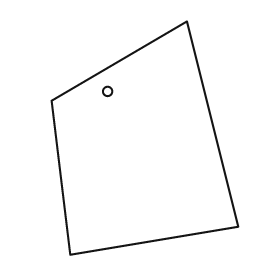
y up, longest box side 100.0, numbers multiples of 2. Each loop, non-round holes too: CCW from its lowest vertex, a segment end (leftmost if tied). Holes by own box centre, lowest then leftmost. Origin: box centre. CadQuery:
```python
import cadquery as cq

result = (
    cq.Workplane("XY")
    .moveTo(-32.0, -50.0)
    .lineTo(40.0, -38.0)
    .lineTo(18.0, 50.0)
    .lineTo(-40.0, 16.0)
    .close()
    .moveTo(-16.0, 20.0)
    .circle(2.0)
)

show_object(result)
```